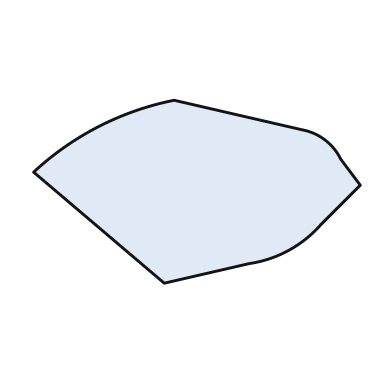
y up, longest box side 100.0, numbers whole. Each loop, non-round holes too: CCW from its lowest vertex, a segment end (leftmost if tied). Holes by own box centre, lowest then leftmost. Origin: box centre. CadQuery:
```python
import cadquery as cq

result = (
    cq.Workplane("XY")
    .moveTo(-10.0, -28.0)
    .lineTo(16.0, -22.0)
    .threePointArc((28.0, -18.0), (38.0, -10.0))
    .lineTo(50.0, 2.0)
    .lineTo(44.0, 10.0)
    .threePointArc((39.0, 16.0), (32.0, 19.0))
    .lineTo(-7.0, 28.0)
    .threePointArc((-30.0, 20.0), (-50.0, 6.0))
    .close()
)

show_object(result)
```